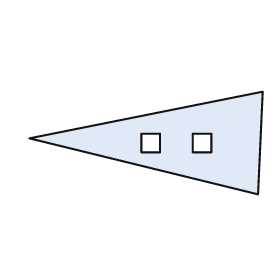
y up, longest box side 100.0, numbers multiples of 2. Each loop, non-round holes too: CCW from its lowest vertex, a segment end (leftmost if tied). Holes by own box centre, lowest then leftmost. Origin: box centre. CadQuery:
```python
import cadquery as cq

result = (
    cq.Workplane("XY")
    .moveTo(48.0, -22.0)
    .lineTo(50.0, 22.0)
    .lineTo(-50.0, 2.0)
    .close()
    .moveTo(-2.0, -4.0)
    .lineTo(6.0, -4.0)
    .lineTo(6.0, 4.0)
    .lineTo(-2.0, 4.0)
    .close()
    .moveTo(20.0, -4.0)
    .lineTo(28.0, -4.0)
    .lineTo(28.0, 4.0)
    .lineTo(20.0, 4.0)
    .close()
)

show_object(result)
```